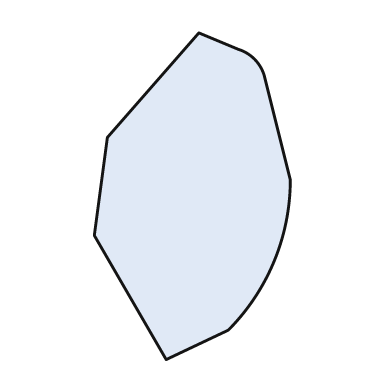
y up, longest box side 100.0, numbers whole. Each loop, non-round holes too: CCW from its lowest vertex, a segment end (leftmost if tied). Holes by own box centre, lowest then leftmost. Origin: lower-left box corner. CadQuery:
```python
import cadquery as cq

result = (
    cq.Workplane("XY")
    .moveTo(22.0, 0.0)
    .lineTo(41.0, 9.0)
    .threePointArc((55.0, 30.0), (60.0, 55.0))
    .lineTo(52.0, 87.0)
    .threePointArc((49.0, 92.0), (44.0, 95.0))
    .lineTo(32.0, 100.0)
    .lineTo(4.0, 68.0)
    .lineTo(0.0, 38.0)
    .close()
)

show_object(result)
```